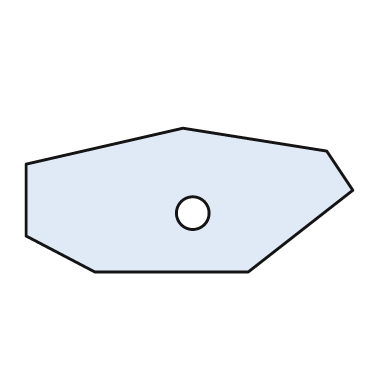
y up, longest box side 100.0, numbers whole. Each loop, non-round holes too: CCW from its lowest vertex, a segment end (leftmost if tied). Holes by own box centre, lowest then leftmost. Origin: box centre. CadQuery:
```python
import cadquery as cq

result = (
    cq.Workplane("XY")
    .moveTo(-29.0, -22.0)
    .lineTo(18.0, -22.0)
    .lineTo(50.0, 3.0)
    .lineTo(42.0, 15.0)
    .lineTo(-2.0, 22.0)
    .lineTo(-50.0, 11.0)
    .lineTo(-50.0, -11.0)
    .close()
    .moveTo(1.0, -4.0)
    .circle(5.0)
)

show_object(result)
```